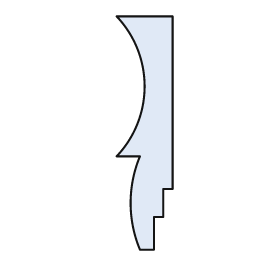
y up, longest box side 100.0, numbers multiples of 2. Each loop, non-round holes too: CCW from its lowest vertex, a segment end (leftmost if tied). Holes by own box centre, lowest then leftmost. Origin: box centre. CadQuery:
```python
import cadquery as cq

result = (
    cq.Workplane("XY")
    .moveTo(-2.0, -50.0)
    .lineTo(4.0, -50.0)
    .lineTo(4.0, -36.0)
    .lineTo(8.0, -36.0)
    .lineTo(8.0, -24.0)
    .lineTo(12.0, -24.0)
    .lineTo(12.0, 50.0)
    .lineTo(-12.0, 50.0)
    .threePointArc((0.0, 20.0), (-12.0, -10.0))
    .lineTo(-2.0, -10.0)
    .threePointArc((-6.0, -30.0), (-2.0, -50.0))
    .close()
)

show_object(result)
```